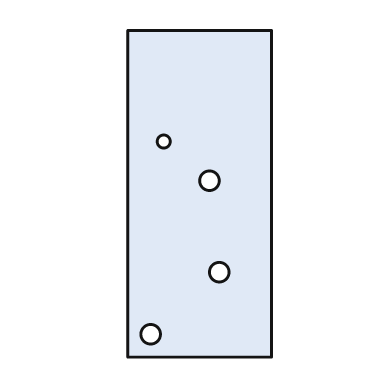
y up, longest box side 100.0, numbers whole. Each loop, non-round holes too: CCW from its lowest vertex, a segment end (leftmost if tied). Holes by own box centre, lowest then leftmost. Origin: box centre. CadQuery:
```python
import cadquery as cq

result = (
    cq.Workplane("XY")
    .moveTo(-22.0, -50.0)
    .lineTo(22.0, -50.0)
    .lineTo(22.0, 50.0)
    .lineTo(-22.0, 50.0)
    .close()
    .moveTo(-15.0, -43.0)
    .circle(3.0)
    .moveTo(6.0, -24.0)
    .circle(3.0)
    .moveTo(3.0, 4.0)
    .circle(3.0)
    .moveTo(-11.0, 16.0)
    .circle(2.0)
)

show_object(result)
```